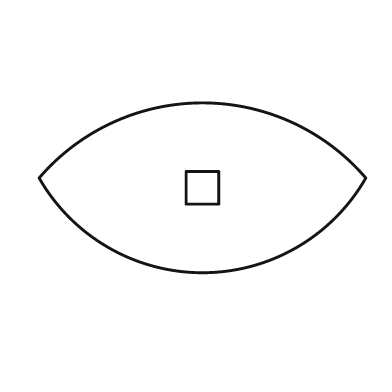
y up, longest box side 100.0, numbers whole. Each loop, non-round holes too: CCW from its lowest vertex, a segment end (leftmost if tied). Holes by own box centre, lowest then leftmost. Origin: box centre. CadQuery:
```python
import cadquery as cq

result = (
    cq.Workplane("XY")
    .moveTo(-50.0, 3.0)
    .threePointArc((0.0, -26.0), (50.0, 3.0))
    .threePointArc((0.0, 26.0), (-50.0, 3.0))
    .close()
    .moveTo(-5.0, -5.0)
    .lineTo(5.0, -5.0)
    .lineTo(5.0, 5.0)
    .lineTo(-5.0, 5.0)
    .close()
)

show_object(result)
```